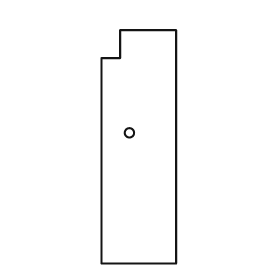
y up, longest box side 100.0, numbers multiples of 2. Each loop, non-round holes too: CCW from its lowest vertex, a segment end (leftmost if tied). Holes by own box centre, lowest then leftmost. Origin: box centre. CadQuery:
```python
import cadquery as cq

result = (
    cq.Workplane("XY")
    .moveTo(-16.0, -50.0)
    .lineTo(16.0, -50.0)
    .lineTo(16.0, 50.0)
    .lineTo(-8.0, 50.0)
    .lineTo(-8.0, 38.0)
    .lineTo(-16.0, 38.0)
    .close()
    .moveTo(-4.0, 6.0)
    .circle(2.0)
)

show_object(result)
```